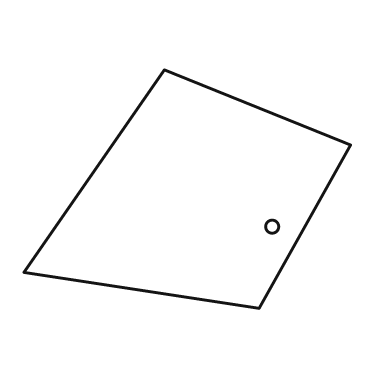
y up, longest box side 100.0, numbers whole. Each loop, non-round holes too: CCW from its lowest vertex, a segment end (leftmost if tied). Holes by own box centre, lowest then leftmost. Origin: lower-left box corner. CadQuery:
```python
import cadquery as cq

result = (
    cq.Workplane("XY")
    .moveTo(72.0, 0.0)
    .lineTo(100.0, 50.0)
    .lineTo(43.0, 73.0)
    .lineTo(0.0, 11.0)
    .close()
    .moveTo(76.0, 25.0)
    .circle(2.0)
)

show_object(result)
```